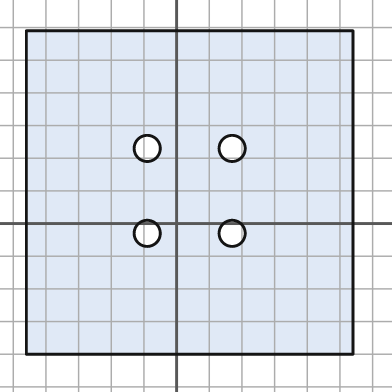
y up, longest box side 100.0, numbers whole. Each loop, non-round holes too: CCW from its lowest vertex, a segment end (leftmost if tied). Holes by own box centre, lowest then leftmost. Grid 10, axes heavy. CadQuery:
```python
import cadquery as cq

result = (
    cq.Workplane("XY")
    .moveTo(-46.0, -40.0)
    .lineTo(54.0, -40.0)
    .lineTo(54.0, 59.0)
    .lineTo(-46.0, 59.0)
    .close()
    .moveTo(-9.0, -3.0)
    .circle(4.0)
    .moveTo(17.0, -3.0)
    .circle(4.0)
    .moveTo(-9.0, 23.0)
    .circle(4.0)
    .moveTo(17.0, 23.0)
    .circle(4.0)
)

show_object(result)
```